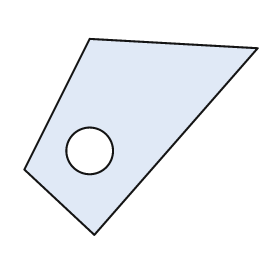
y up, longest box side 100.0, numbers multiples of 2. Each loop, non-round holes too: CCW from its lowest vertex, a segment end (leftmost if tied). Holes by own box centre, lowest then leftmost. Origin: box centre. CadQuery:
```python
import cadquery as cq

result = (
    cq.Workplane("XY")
    .moveTo(-20.0, -42.0)
    .lineTo(50.0, 38.0)
    .lineTo(-22.0, 42.0)
    .lineTo(-50.0, -14.0)
    .close()
    .moveTo(-22.0, -6.0)
    .circle(10.0)
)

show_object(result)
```